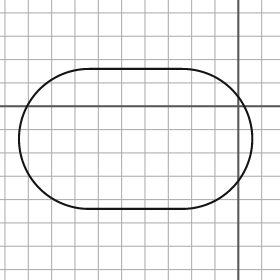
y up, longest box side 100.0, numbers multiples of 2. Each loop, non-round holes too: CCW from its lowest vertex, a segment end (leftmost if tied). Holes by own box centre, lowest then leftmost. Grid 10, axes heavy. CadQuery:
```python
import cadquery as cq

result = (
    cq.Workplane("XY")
    .moveTo(-64.0, -44.0)
    .lineTo(-24.0, -44.0)
    .threePointArc((6.0, -14.0), (-24.0, 16.0))
    .lineTo(-64.0, 16.0)
    .threePointArc((-94.0, -14.0), (-64.0, -44.0))
    .close()
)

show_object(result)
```